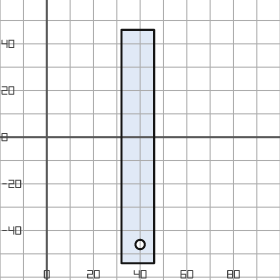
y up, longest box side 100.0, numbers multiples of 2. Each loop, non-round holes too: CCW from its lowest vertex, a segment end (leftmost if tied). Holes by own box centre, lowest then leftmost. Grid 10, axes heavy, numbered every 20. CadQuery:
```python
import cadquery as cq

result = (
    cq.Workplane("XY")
    .moveTo(32.0, -54.0)
    .lineTo(46.0, -54.0)
    .lineTo(46.0, 46.0)
    .lineTo(32.0, 46.0)
    .close()
    .moveTo(40.0, -46.0)
    .circle(2.0)
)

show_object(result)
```